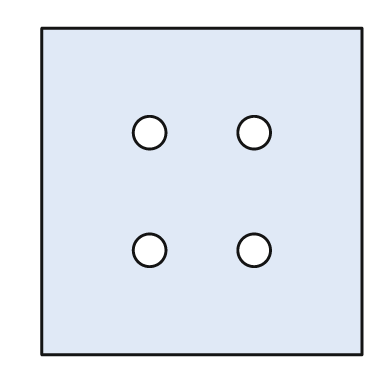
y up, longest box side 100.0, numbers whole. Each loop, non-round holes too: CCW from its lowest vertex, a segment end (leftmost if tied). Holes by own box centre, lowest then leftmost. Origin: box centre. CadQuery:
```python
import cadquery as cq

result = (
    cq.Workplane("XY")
    .moveTo(-49.0, -50.0)
    .lineTo(49.0, -50.0)
    .lineTo(49.0, 50.0)
    .lineTo(-49.0, 50.0)
    .close()
    .moveTo(-16.0, -18.0)
    .circle(5.0)
    .moveTo(16.0, -18.0)
    .circle(5.0)
    .moveTo(-16.0, 18.0)
    .circle(5.0)
    .moveTo(16.0, 18.0)
    .circle(5.0)
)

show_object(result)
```